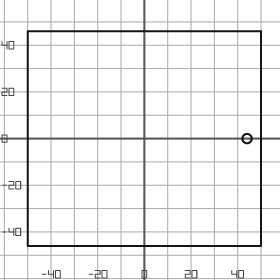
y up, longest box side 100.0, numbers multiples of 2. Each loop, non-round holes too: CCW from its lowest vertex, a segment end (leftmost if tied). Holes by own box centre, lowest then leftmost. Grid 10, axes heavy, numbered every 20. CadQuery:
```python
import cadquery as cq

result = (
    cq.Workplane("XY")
    .moveTo(-50.0, -46.0)
    .lineTo(50.0, -46.0)
    .lineTo(50.0, 46.0)
    .lineTo(-50.0, 46.0)
    .close()
    .moveTo(44.0, 0.0)
    .circle(2.0)
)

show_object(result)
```